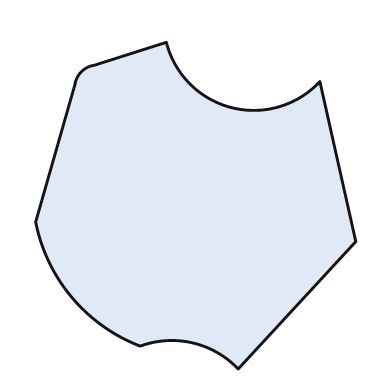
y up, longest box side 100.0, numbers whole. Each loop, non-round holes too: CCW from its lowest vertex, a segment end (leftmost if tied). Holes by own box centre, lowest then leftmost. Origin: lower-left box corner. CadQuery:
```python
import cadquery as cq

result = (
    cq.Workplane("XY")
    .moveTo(62.0, 0.0)
    .lineTo(98.0, 39.0)
    .lineTo(87.0, 88.0)
    .threePointArc((60.0, 80.0), (40.0, 100.0))
    .lineTo(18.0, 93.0)
    .threePointArc((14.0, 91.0), (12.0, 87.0))
    .lineTo(0.0, 45.0)
    .threePointArc((11.0, 22.0), (32.0, 7.0))
    .threePointArc((48.0, 8.0), (62.0, 0.0))
    .close()
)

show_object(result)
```